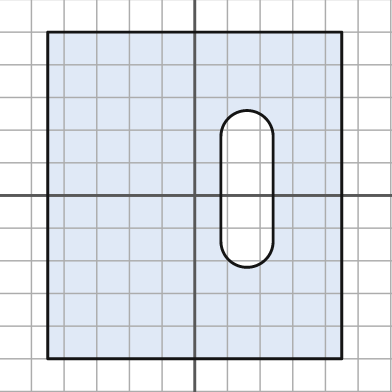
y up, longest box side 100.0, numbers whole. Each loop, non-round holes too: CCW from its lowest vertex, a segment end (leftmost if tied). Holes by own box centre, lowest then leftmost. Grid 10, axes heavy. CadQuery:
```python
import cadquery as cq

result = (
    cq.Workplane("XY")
    .moveTo(-45.0, -50.0)
    .lineTo(45.0, -50.0)
    .lineTo(45.0, 50.0)
    .lineTo(-45.0, 50.0)
    .close()
    .moveTo(8.0, -14.0)
    .threePointArc((16.0, -22.0), (24.0, -14.0))
    .lineTo(24.0, 18.0)
    .threePointArc((16.0, 26.0), (8.0, 18.0))
    .close()
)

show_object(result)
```